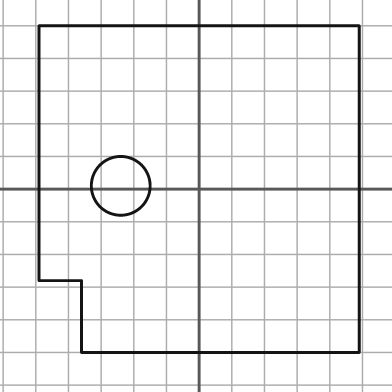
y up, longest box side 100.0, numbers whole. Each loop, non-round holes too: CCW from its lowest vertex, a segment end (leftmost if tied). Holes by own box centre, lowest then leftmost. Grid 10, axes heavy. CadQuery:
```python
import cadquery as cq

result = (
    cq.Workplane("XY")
    .moveTo(-36.0, -50.0)
    .lineTo(49.0, -50.0)
    .lineTo(49.0, 50.0)
    .lineTo(-49.0, 50.0)
    .lineTo(-49.0, -28.0)
    .lineTo(-36.0, -28.0)
    .close()
    .moveTo(-24.0, 1.0)
    .circle(9.0)
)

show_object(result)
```